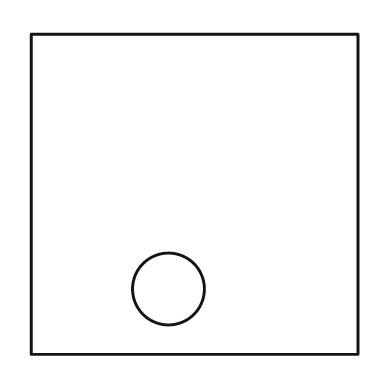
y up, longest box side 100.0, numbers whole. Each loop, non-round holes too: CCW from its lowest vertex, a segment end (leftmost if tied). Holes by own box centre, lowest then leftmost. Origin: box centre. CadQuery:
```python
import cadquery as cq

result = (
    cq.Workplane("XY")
    .moveTo(-50.0, -49.0)
    .lineTo(50.0, -49.0)
    .lineTo(50.0, 49.0)
    .lineTo(-50.0, 49.0)
    .close()
    .moveTo(-8.0, -29.0)
    .circle(11.0)
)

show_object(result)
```